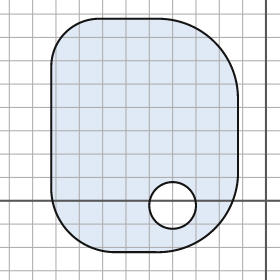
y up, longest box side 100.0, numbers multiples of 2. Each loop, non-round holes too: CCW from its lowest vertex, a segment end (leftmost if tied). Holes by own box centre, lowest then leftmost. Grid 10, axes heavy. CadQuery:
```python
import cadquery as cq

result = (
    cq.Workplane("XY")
    .moveTo(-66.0, -22.0)
    .lineTo(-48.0, -22.0)
    .threePointArc((-22.0, -12.0), (-12.0, 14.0))
    .lineTo(-12.0, 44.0)
    .threePointArc((-22.0, 68.0), (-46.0, 78.0))
    .lineTo(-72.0, 78.0)
    .threePointArc((-86.0, 72.0), (-92.0, 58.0))
    .lineTo(-92.0, 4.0)
    .threePointArc((-84.0, -14.0), (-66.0, -22.0))
    .close()
    .moveTo(-40.0, -2.0)
    .circle(10.0)
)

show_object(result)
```